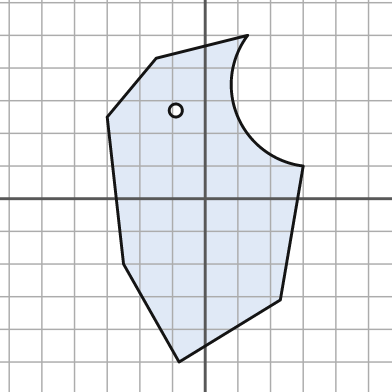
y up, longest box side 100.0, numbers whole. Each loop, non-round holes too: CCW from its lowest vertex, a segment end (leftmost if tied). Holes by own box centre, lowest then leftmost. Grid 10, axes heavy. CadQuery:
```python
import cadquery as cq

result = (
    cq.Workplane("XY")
    .moveTo(-8.0, -50.0)
    .lineTo(23.0, -31.0)
    .lineTo(30.0, 10.0)
    .threePointArc((10.0, 25.0), (13.0, 50.0))
    .lineTo(-15.0, 43.0)
    .lineTo(-30.0, 25.0)
    .lineTo(-25.0, -20.0)
    .close()
    .moveTo(-9.0, 27.0)
    .circle(2.0)
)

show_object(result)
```